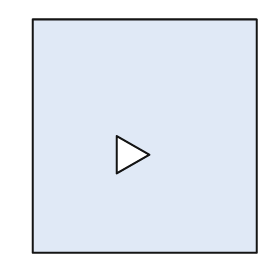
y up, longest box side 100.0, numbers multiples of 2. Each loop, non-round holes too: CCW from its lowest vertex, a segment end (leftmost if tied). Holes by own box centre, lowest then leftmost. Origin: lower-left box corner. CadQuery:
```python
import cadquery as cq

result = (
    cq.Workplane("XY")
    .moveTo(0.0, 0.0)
    .lineTo(96.0, 0.0)
    .lineTo(96.0, 100.0)
    .lineTo(0.0, 100.0)
    .close()
    .moveTo(36.0, 34.0)
    .lineTo(50.0, 42.0)
    .lineTo(36.0, 50.0)
    .close()
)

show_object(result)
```